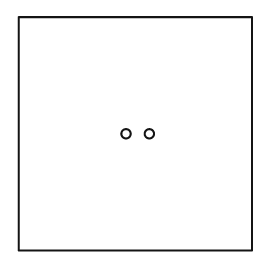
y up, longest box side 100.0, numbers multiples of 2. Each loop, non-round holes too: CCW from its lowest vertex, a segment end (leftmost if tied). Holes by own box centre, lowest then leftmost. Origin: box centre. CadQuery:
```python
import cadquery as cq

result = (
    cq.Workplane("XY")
    .moveTo(-50.0, -50.0)
    .lineTo(50.0, -50.0)
    .lineTo(50.0, 50.0)
    .lineTo(-50.0, 50.0)
    .close()
    .moveTo(-4.0, 0.0)
    .circle(2.0)
    .moveTo(6.0, 0.0)
    .circle(2.0)
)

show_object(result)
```